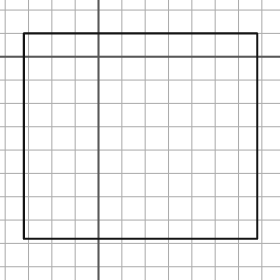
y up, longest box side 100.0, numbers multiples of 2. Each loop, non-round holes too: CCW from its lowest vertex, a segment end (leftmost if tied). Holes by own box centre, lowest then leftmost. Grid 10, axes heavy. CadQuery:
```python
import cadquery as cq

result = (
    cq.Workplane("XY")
    .moveTo(-32.0, -78.0)
    .lineTo(68.0, -78.0)
    .lineTo(68.0, 10.0)
    .lineTo(-32.0, 10.0)
    .close()
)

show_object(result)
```